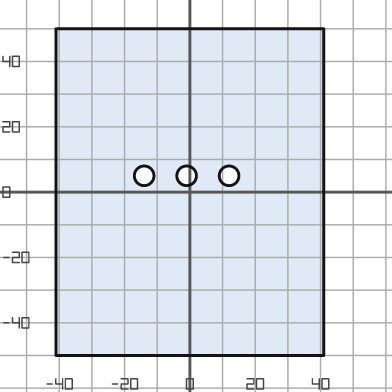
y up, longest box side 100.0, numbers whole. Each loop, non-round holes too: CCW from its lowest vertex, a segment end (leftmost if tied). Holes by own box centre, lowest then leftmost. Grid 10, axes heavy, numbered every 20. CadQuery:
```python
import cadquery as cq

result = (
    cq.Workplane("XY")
    .moveTo(-41.0, -50.0)
    .lineTo(41.0, -50.0)
    .lineTo(41.0, 50.0)
    .lineTo(-41.0, 50.0)
    .close()
    .moveTo(-14.0, 5.0)
    .circle(3.0)
    .moveTo(-1.0, 5.0)
    .circle(3.0)
    .moveTo(12.0, 5.0)
    .circle(3.0)
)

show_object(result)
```